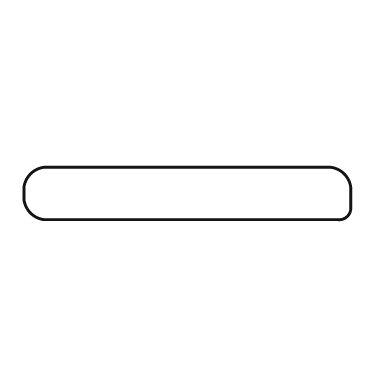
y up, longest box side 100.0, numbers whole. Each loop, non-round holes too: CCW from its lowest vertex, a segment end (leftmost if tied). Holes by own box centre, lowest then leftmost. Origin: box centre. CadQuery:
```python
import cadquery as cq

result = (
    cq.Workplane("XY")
    .moveTo(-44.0, -8.0)
    .lineTo(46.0, -8.0)
    .threePointArc((49.0, -7.0), (50.0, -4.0))
    .lineTo(50.0, 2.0)
    .threePointArc((48.0, 6.0), (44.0, 8.0))
    .lineTo(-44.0, 8.0)
    .threePointArc((-48.0, 6.0), (-50.0, 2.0))
    .lineTo(-50.0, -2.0)
    .threePointArc((-48.0, -6.0), (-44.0, -8.0))
    .close()
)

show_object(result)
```